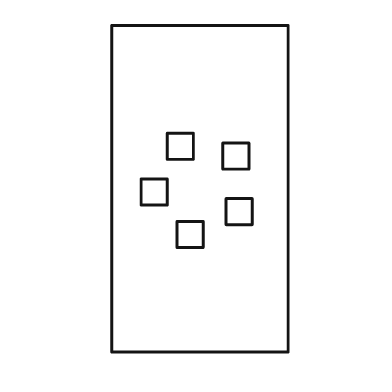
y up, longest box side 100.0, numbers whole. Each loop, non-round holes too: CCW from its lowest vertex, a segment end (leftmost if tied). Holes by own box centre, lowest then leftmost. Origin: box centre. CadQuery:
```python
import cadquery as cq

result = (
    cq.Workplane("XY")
    .moveTo(-27.0, -50.0)
    .lineTo(27.0, -50.0)
    .lineTo(27.0, 50.0)
    .lineTo(-27.0, 50.0)
    .close()
    .moveTo(-7.0, -18.0)
    .lineTo(1.0, -18.0)
    .lineTo(1.0, -10.0)
    .lineTo(-7.0, -10.0)
    .close()
    .moveTo(8.0, -11.0)
    .lineTo(16.0, -11.0)
    .lineTo(16.0, -3.0)
    .lineTo(8.0, -3.0)
    .close()
    .moveTo(-18.0, -5.0)
    .lineTo(-10.0, -5.0)
    .lineTo(-10.0, 3.0)
    .lineTo(-18.0, 3.0)
    .close()
    .moveTo(7.0, 6.0)
    .lineTo(15.0, 6.0)
    .lineTo(15.0, 14.0)
    .lineTo(7.0, 14.0)
    .close()
    .moveTo(-10.0, 9.0)
    .lineTo(-2.0, 9.0)
    .lineTo(-2.0, 17.0)
    .lineTo(-10.0, 17.0)
    .close()
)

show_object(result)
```